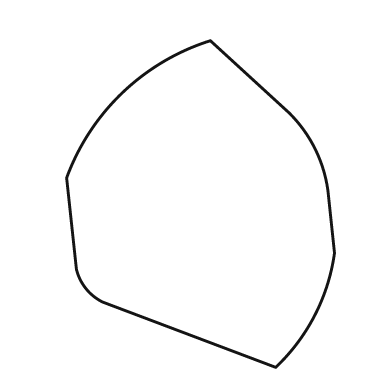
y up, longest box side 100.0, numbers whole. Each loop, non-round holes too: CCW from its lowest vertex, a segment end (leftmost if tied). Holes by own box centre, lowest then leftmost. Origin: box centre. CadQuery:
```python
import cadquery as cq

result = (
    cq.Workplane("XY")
    .moveTo(23.0, -50.0)
    .threePointArc((35.0, -34.0), (41.0, -15.0))
    .lineTo(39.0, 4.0)
    .threePointArc((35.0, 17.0), (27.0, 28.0))
    .lineTo(3.0, 50.0)
    .threePointArc((-24.0, 34.0), (-41.0, 8.0))
    .lineTo(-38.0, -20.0)
    .threePointArc((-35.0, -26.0), (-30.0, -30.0))
    .close()
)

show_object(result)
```